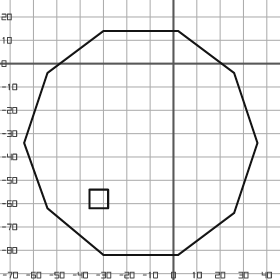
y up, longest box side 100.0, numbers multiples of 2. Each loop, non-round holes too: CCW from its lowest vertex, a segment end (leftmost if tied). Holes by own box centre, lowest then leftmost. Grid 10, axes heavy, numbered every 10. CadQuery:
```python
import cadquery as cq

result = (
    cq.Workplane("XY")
    .moveTo(-30.0, -82.0)
    .lineTo(2.0, -82.0)
    .lineTo(26.0, -64.0)
    .lineTo(36.0, -34.0)
    .lineTo(26.0, -4.0)
    .lineTo(2.0, 14.0)
    .lineTo(-30.0, 14.0)
    .lineTo(-54.0, -4.0)
    .lineTo(-64.0, -34.0)
    .lineTo(-54.0, -62.0)
    .close()
    .moveTo(-36.0, -62.0)
    .lineTo(-28.0, -62.0)
    .lineTo(-28.0, -54.0)
    .lineTo(-36.0, -54.0)
    .close()
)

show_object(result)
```